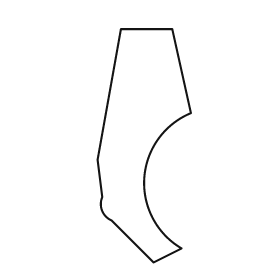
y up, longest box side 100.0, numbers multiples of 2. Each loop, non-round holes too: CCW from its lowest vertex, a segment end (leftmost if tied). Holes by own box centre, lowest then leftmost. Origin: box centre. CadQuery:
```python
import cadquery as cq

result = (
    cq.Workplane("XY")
    .moveTo(4.0, -50.0)
    .lineTo(16.0, -44.0)
    .threePointArc((0.0, -14.0), (20.0, 14.0))
    .lineTo(12.0, 50.0)
    .lineTo(-10.0, 50.0)
    .lineTo(-20.0, -6.0)
    .lineTo(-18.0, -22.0)
    .threePointArc((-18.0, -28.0), (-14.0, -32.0))
    .close()
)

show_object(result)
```